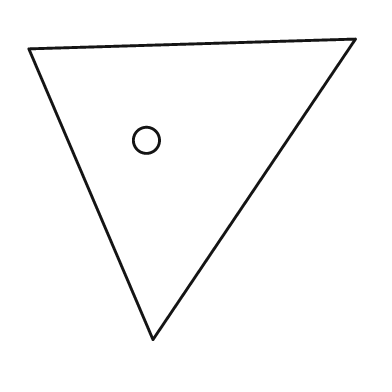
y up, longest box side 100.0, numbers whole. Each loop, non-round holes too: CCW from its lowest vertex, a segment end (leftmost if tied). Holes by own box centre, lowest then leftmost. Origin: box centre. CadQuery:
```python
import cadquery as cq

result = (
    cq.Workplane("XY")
    .moveTo(-12.0, -46.0)
    .lineTo(50.0, 46.0)
    .lineTo(-50.0, 43.0)
    .close()
    .moveTo(-14.0, 15.0)
    .circle(4.0)
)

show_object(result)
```